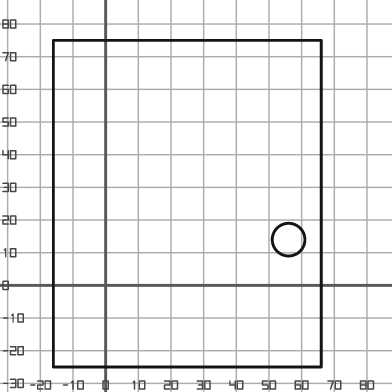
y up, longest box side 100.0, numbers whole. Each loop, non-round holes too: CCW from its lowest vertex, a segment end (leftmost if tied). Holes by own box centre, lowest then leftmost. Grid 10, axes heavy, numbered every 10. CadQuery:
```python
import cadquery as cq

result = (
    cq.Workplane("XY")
    .moveTo(-16.0, -25.0)
    .lineTo(66.0, -25.0)
    .lineTo(66.0, 75.0)
    .lineTo(-16.0, 75.0)
    .close()
    .moveTo(56.0, 14.0)
    .circle(5.0)
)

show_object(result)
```